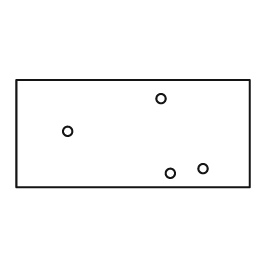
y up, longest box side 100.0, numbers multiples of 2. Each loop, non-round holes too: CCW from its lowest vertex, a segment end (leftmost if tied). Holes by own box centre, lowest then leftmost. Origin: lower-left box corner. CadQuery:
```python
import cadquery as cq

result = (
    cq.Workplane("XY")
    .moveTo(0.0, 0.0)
    .lineTo(100.0, 0.0)
    .lineTo(100.0, 46.0)
    .lineTo(0.0, 46.0)
    .close()
    .moveTo(66.0, 6.0)
    .circle(2.0)
    .moveTo(80.0, 8.0)
    .circle(2.0)
    .moveTo(22.0, 24.0)
    .circle(2.0)
    .moveTo(62.0, 38.0)
    .circle(2.0)
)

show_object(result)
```